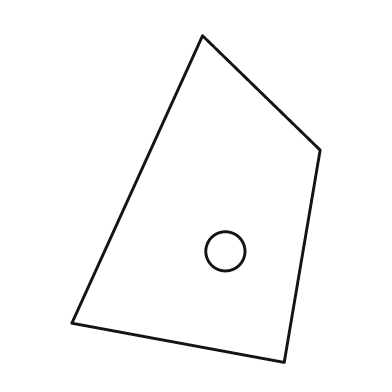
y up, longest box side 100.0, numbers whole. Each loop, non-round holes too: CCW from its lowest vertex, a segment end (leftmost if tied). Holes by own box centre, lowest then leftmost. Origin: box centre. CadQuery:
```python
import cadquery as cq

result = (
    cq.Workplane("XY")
    .moveTo(27.0, -50.0)
    .lineTo(38.0, 15.0)
    .lineTo(2.0, 50.0)
    .lineTo(-38.0, -38.0)
    .close()
    .moveTo(9.0, -16.0)
    .circle(6.0)
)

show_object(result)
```